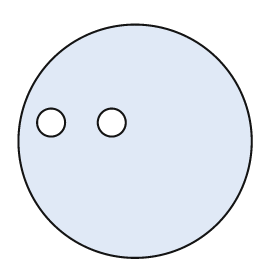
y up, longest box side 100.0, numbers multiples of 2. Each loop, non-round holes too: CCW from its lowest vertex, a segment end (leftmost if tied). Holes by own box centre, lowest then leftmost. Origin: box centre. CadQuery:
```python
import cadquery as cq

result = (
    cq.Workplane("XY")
    .moveTo(0.0, 0.0)
    .circle(50.0)
    .moveTo(-36.0, 8.0)
    .circle(6.0)
    .moveTo(-10.0, 8.0)
    .circle(6.0)
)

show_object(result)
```